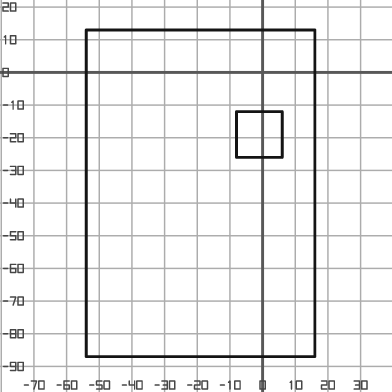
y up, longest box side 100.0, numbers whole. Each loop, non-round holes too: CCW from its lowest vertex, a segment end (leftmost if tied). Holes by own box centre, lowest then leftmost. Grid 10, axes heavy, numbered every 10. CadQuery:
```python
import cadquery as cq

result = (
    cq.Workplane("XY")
    .moveTo(-54.0, -87.0)
    .lineTo(16.0, -87.0)
    .lineTo(16.0, 13.0)
    .lineTo(-54.0, 13.0)
    .close()
    .moveTo(-8.0, -26.0)
    .lineTo(6.0, -26.0)
    .lineTo(6.0, -12.0)
    .lineTo(-8.0, -12.0)
    .close()
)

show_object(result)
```